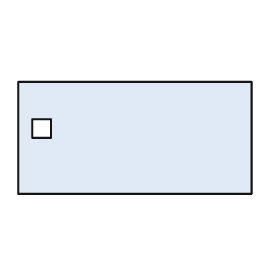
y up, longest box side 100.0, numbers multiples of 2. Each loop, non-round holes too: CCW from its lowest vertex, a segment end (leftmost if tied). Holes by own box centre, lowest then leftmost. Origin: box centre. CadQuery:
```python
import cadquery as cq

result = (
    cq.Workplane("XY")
    .moveTo(-50.0, -24.0)
    .lineTo(50.0, -24.0)
    .lineTo(50.0, 24.0)
    .lineTo(-50.0, 24.0)
    .close()
    .moveTo(-44.0, 0.0)
    .lineTo(-36.0, 0.0)
    .lineTo(-36.0, 8.0)
    .lineTo(-44.0, 8.0)
    .close()
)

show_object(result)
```